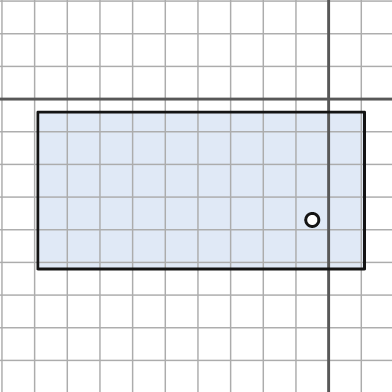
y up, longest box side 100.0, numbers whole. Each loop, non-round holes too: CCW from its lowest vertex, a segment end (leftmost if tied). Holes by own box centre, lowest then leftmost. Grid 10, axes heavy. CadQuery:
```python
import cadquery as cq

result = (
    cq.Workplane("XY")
    .moveTo(-89.0, -52.0)
    .lineTo(11.0, -52.0)
    .lineTo(11.0, -4.0)
    .lineTo(-89.0, -4.0)
    .close()
    .moveTo(-5.0, -37.0)
    .circle(2.0)
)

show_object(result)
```